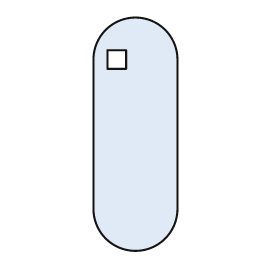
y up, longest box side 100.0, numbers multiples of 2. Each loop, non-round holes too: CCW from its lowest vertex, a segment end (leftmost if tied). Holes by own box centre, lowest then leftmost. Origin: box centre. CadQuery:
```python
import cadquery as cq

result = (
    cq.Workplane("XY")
    .moveTo(-18.0, -32.0)
    .threePointArc((0.0, -50.0), (18.0, -32.0))
    .lineTo(18.0, 32.0)
    .threePointArc((0.0, 50.0), (-18.0, 32.0))
    .close()
    .moveTo(-12.0, 28.0)
    .lineTo(-4.0, 28.0)
    .lineTo(-4.0, 36.0)
    .lineTo(-12.0, 36.0)
    .close()
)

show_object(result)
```